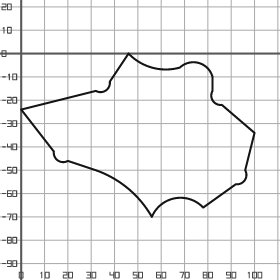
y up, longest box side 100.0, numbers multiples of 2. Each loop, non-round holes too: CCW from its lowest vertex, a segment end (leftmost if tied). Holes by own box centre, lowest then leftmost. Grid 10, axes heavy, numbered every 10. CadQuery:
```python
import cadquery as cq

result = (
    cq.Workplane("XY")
    .moveTo(56.0, -70.0)
    .threePointArc((66.0, -62.0), (78.0, -66.0))
    .lineTo(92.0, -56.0)
    .threePointArc((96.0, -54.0), (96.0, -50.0))
    .lineTo(100.0, -34.0)
    .lineTo(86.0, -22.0)
    .threePointArc((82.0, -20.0), (82.0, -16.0))
    .lineTo(82.0, -10.0)
    .threePointArc((76.0, -4.0), (68.0, -6.0))
    .threePointArc((56.0, -6.0), (46.0, 0.0))
    .lineTo(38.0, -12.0)
    .threePointArc((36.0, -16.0), (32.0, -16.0))
    .lineTo(0.0, -24.0)
    .lineTo(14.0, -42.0)
    .threePointArc((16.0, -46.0), (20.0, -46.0))
    .lineTo(32.0, -50.0)
    .threePointArc((46.0, -58.0), (56.0, -70.0))
    .close()
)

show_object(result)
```